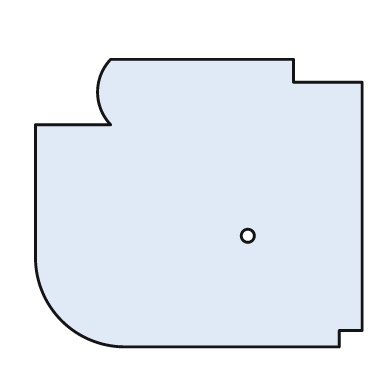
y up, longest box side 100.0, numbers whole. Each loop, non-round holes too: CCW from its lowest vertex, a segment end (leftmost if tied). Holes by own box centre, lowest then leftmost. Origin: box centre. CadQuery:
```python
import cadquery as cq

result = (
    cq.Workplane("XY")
    .moveTo(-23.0, -44.0)
    .lineTo(43.0, -44.0)
    .lineTo(43.0, -39.0)
    .lineTo(50.0, -39.0)
    .lineTo(50.0, 37.0)
    .lineTo(29.0, 37.0)
    .lineTo(29.0, 44.0)
    .lineTo(-27.0, 44.0)
    .threePointArc((-31.0, 34.0), (-27.0, 24.0))
    .lineTo(-50.0, 24.0)
    .lineTo(-50.0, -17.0)
    .threePointArc((-42.0, -36.0), (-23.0, -44.0))
    .close()
    .moveTo(15.0, -10.0)
    .circle(2.0)
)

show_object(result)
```